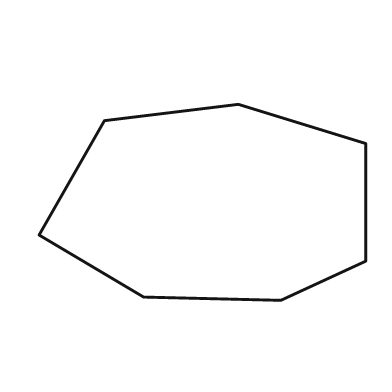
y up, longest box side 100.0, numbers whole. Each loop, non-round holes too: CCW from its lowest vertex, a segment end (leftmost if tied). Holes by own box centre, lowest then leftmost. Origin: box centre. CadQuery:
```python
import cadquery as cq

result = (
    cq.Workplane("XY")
    .moveTo(24.0, -30.0)
    .lineTo(50.0, -18.0)
    .lineTo(50.0, 18.0)
    .lineTo(11.0, 30.0)
    .lineTo(-30.0, 25.0)
    .lineTo(-50.0, -10.0)
    .lineTo(-18.0, -29.0)
    .close()
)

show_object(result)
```